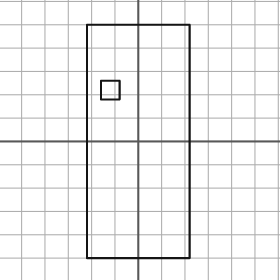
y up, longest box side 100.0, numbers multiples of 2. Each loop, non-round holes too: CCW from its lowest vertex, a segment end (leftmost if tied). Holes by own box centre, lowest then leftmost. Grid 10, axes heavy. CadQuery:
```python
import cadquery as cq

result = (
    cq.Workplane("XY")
    .moveTo(-22.0, -50.0)
    .lineTo(22.0, -50.0)
    .lineTo(22.0, 50.0)
    .lineTo(-22.0, 50.0)
    .close()
    .moveTo(-16.0, 18.0)
    .lineTo(-8.0, 18.0)
    .lineTo(-8.0, 26.0)
    .lineTo(-16.0, 26.0)
    .close()
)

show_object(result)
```